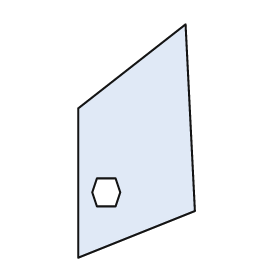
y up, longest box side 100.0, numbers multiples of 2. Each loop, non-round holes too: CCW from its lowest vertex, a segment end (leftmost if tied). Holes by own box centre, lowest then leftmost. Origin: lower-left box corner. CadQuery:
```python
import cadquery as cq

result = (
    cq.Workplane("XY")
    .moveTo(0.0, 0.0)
    .lineTo(50.0, 20.0)
    .lineTo(46.0, 100.0)
    .lineTo(0.0, 64.0)
    .close()
    .moveTo(8.0, 22.0)
    .lineTo(16.0, 22.0)
    .lineTo(18.0, 28.0)
    .lineTo(16.0, 34.0)
    .lineTo(8.0, 34.0)
    .lineTo(6.0, 28.0)
    .close()
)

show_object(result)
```